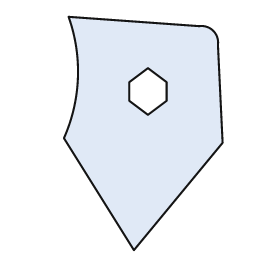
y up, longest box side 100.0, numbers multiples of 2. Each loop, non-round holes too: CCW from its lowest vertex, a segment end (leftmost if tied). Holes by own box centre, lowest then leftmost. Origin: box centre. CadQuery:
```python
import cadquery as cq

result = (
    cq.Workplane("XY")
    .moveTo(-4.0, -50.0)
    .lineTo(34.0, -4.0)
    .lineTo(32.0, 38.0)
    .threePointArc((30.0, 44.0), (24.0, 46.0))
    .lineTo(-32.0, 50.0)
    .threePointArc((-28.0, 24.0), (-34.0, -2.0))
    .close()
    .moveTo(2.0, 8.0)
    .lineTo(10.0, 14.0)
    .lineTo(10.0, 22.0)
    .lineTo(2.0, 28.0)
    .lineTo(-6.0, 22.0)
    .lineTo(-6.0, 14.0)
    .close()
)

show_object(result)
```